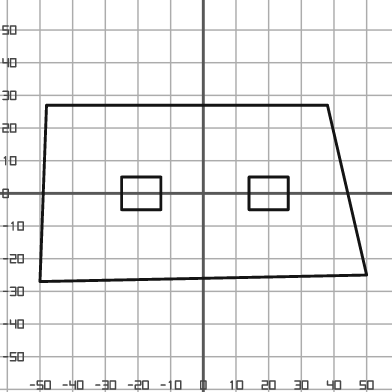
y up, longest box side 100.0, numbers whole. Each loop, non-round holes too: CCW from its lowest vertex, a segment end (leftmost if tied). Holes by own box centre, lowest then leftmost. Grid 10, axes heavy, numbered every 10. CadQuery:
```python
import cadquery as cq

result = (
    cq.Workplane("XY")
    .moveTo(-50.0, -27.0)
    .lineTo(50.0, -25.0)
    .lineTo(38.0, 27.0)
    .lineTo(-48.0, 27.0)
    .close()
    .moveTo(-25.0, -5.0)
    .lineTo(-13.0, -5.0)
    .lineTo(-13.0, 5.0)
    .lineTo(-25.0, 5.0)
    .close()
    .moveTo(14.0, -5.0)
    .lineTo(26.0, -5.0)
    .lineTo(26.0, 5.0)
    .lineTo(14.0, 5.0)
    .close()
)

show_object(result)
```